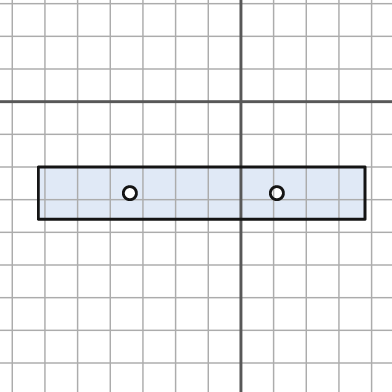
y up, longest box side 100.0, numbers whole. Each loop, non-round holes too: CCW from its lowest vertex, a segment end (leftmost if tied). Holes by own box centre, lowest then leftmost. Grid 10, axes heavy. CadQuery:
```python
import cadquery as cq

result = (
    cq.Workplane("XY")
    .moveTo(-62.0, -36.0)
    .lineTo(38.0, -36.0)
    .lineTo(38.0, -20.0)
    .lineTo(-62.0, -20.0)
    .close()
    .moveTo(-34.0, -28.0)
    .circle(2.0)
    .moveTo(11.0, -28.0)
    .circle(2.0)
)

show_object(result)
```